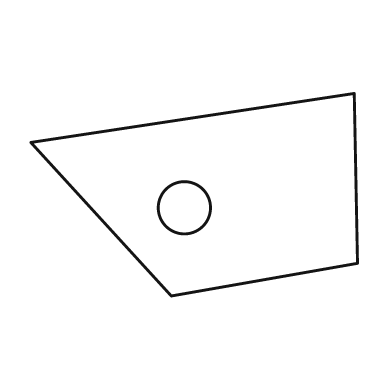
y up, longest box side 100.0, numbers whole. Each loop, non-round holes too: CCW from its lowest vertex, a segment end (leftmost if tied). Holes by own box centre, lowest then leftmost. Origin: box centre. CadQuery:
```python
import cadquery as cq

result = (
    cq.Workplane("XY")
    .moveTo(-7.0, -31.0)
    .lineTo(50.0, -21.0)
    .lineTo(49.0, 31.0)
    .lineTo(-50.0, 16.0)
    .close()
    .moveTo(-3.0, -4.0)
    .circle(8.0)
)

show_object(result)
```